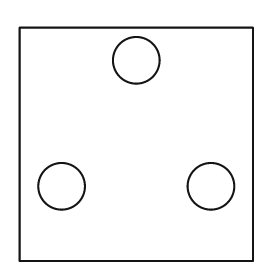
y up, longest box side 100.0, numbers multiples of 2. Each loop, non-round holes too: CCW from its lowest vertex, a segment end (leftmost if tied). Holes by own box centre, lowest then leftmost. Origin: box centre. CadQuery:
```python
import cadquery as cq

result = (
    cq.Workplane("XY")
    .moveTo(-50.0, -50.0)
    .lineTo(50.0, -50.0)
    .lineTo(50.0, 50.0)
    .lineTo(-50.0, 50.0)
    .close()
    .moveTo(-32.0, -18.0)
    .circle(10.0)
    .moveTo(32.0, -18.0)
    .circle(10.0)
    .moveTo(0.0, 36.0)
    .circle(10.0)
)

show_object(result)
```